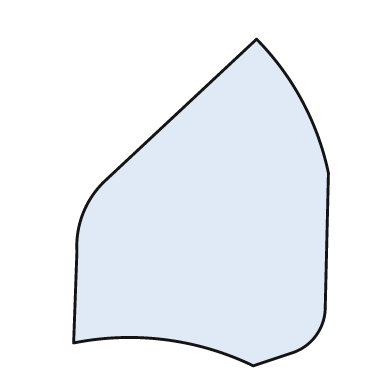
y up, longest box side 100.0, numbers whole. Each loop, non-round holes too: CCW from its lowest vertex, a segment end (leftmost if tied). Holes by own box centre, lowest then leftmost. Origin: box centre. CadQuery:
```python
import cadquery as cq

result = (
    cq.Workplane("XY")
    .moveTo(16.0, -50.0)
    .lineTo(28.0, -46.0)
    .threePointArc((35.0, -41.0), (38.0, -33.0))
    .lineTo(39.0, 9.0)
    .threePointArc((31.0, 31.0), (17.0, 50.0))
    .lineTo(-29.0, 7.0)
    .threePointArc((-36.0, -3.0), (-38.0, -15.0))
    .lineTo(-39.0, -43.0)
    .threePointArc((-11.0, -42.0), (16.0, -50.0))
    .close()
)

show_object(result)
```